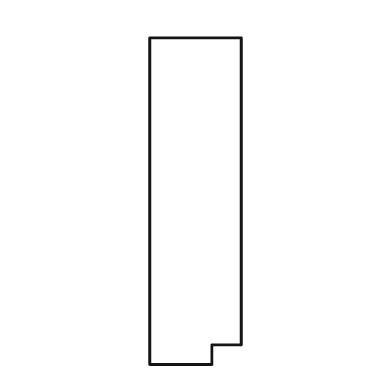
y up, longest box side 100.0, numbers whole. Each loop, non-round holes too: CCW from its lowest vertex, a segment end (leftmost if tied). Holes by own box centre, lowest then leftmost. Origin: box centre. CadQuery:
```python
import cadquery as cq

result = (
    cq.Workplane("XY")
    .moveTo(-14.0, -50.0)
    .lineTo(5.0, -50.0)
    .lineTo(5.0, -44.0)
    .lineTo(14.0, -44.0)
    .lineTo(14.0, 50.0)
    .lineTo(-14.0, 50.0)
    .close()
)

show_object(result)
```